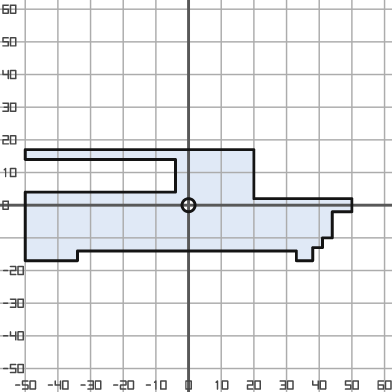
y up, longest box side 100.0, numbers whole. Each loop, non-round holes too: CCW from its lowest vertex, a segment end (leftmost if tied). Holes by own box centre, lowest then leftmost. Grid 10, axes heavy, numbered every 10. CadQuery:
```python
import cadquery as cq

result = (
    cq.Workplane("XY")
    .moveTo(-50.0, -17.0)
    .lineTo(-34.0, -17.0)
    .lineTo(-34.0, -14.0)
    .lineTo(33.0, -14.0)
    .lineTo(33.0, -17.0)
    .lineTo(38.0, -17.0)
    .lineTo(38.0, -13.0)
    .lineTo(41.0, -13.0)
    .lineTo(41.0, -10.0)
    .lineTo(44.0, -10.0)
    .lineTo(44.0, -2.0)
    .lineTo(50.0, -2.0)
    .lineTo(50.0, 2.0)
    .lineTo(20.0, 2.0)
    .lineTo(20.0, 17.0)
    .lineTo(-50.0, 17.0)
    .lineTo(-50.0, 14.0)
    .lineTo(-4.0, 14.0)
    .lineTo(-4.0, 4.0)
    .lineTo(-50.0, 4.0)
    .close()
    .moveTo(0.0, 0.0)
    .circle(2.0)
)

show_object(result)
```